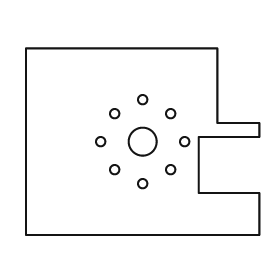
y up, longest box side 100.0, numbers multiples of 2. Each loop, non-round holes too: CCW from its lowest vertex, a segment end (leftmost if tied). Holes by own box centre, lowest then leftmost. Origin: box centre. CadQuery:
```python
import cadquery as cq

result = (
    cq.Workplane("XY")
    .moveTo(-50.0, -40.0)
    .lineTo(50.0, -40.0)
    .lineTo(50.0, -22.0)
    .lineTo(24.0, -22.0)
    .lineTo(24.0, 2.0)
    .lineTo(50.0, 2.0)
    .lineTo(50.0, 8.0)
    .lineTo(32.0, 8.0)
    .lineTo(32.0, 40.0)
    .lineTo(-50.0, 40.0)
    .close()
    .moveTo(0.0, -18.0)
    .circle(2.0)
    .moveTo(-12.0, -12.0)
    .circle(2.0)
    .moveTo(12.0, -12.0)
    .circle(2.0)
    .moveTo(-18.0, 0.0)
    .circle(2.0)
    .moveTo(0.0, 0.0)
    .circle(6.0)
    .moveTo(18.0, 0.0)
    .circle(2.0)
    .moveTo(-12.0, 12.0)
    .circle(2.0)
    .moveTo(12.0, 12.0)
    .circle(2.0)
    .moveTo(0.0, 18.0)
    .circle(2.0)
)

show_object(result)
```